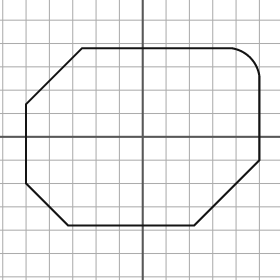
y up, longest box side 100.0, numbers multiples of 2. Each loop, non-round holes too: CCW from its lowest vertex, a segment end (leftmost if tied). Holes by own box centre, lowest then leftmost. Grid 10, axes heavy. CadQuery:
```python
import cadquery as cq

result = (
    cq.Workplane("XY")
    .moveTo(-32.0, -38.0)
    .lineTo(22.0, -38.0)
    .lineTo(50.0, -10.0)
    .lineTo(50.0, 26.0)
    .threePointArc((46.0, 34.0), (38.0, 38.0))
    .lineTo(-26.0, 38.0)
    .lineTo(-50.0, 14.0)
    .lineTo(-50.0, -20.0)
    .close()
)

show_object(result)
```